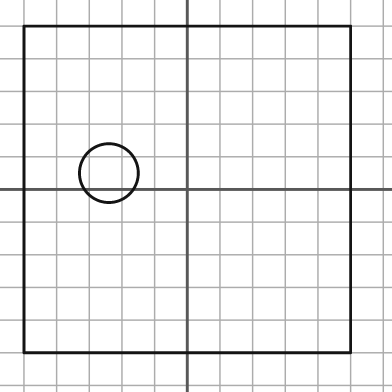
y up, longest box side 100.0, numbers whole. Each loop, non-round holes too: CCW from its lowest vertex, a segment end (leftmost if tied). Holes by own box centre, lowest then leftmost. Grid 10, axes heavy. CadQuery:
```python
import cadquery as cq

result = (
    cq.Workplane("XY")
    .moveTo(-50.0, -50.0)
    .lineTo(50.0, -50.0)
    .lineTo(50.0, 50.0)
    .lineTo(-50.0, 50.0)
    .close()
    .moveTo(-24.0, 5.0)
    .circle(9.0)
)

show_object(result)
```